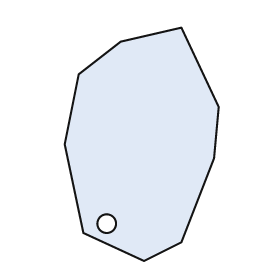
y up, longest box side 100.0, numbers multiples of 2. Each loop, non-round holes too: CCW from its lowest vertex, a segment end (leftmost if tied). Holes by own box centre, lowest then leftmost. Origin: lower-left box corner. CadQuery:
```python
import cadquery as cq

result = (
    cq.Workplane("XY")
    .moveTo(34.0, 0.0)
    .lineTo(50.0, 8.0)
    .lineTo(64.0, 44.0)
    .lineTo(66.0, 66.0)
    .lineTo(50.0, 100.0)
    .lineTo(24.0, 94.0)
    .lineTo(6.0, 80.0)
    .lineTo(0.0, 50.0)
    .lineTo(8.0, 12.0)
    .close()
    .moveTo(18.0, 16.0)
    .circle(4.0)
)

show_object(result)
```